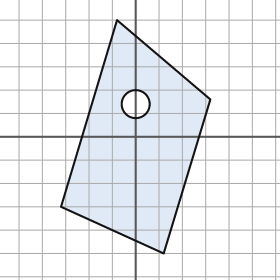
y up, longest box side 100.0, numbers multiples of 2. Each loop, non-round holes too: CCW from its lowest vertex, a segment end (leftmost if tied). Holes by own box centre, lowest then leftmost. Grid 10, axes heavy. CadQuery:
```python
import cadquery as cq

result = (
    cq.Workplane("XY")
    .moveTo(12.0, -50.0)
    .lineTo(32.0, 16.0)
    .lineTo(-8.0, 50.0)
    .lineTo(-32.0, -30.0)
    .close()
    .moveTo(0.0, 14.0)
    .circle(6.0)
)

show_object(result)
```